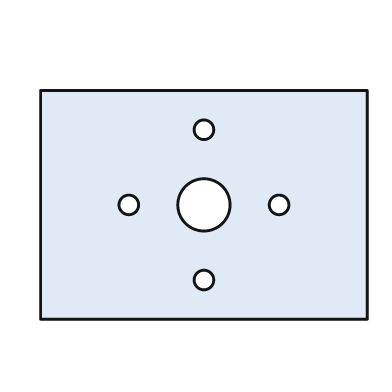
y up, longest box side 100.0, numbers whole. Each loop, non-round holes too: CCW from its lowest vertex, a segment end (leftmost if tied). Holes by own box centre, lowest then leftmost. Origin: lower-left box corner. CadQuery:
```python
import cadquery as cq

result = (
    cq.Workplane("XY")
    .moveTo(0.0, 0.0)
    .lineTo(100.0, 0.0)
    .lineTo(100.0, 70.0)
    .lineTo(0.0, 70.0)
    .close()
    .moveTo(50.0, 12.0)
    .circle(3.0)
    .moveTo(27.0, 35.0)
    .circle(3.0)
    .moveTo(50.0, 35.0)
    .circle(8.0)
    .moveTo(73.0, 35.0)
    .circle(3.0)
    .moveTo(50.0, 58.0)
    .circle(3.0)
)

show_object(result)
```